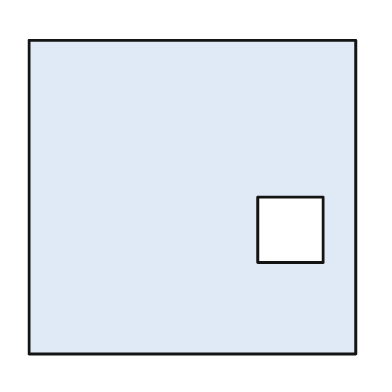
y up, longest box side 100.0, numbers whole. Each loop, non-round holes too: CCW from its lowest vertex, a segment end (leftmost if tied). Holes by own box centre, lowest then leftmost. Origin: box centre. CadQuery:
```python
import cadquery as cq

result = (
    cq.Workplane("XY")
    .moveTo(-50.0, -48.0)
    .lineTo(50.0, -48.0)
    .lineTo(50.0, 48.0)
    .lineTo(-50.0, 48.0)
    .close()
    .moveTo(20.0, -20.0)
    .lineTo(40.0, -20.0)
    .lineTo(40.0, 0.0)
    .lineTo(20.0, 0.0)
    .close()
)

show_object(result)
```